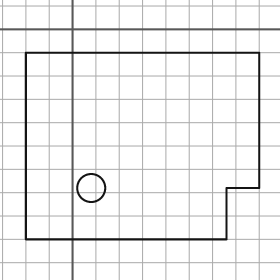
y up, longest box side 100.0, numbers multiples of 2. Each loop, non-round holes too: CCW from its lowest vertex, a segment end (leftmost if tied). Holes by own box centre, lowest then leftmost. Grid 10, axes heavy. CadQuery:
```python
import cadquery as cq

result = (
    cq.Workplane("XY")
    .moveTo(-20.0, -90.0)
    .lineTo(66.0, -90.0)
    .lineTo(66.0, -68.0)
    .lineTo(80.0, -68.0)
    .lineTo(80.0, -10.0)
    .lineTo(-20.0, -10.0)
    .close()
    .moveTo(8.0, -68.0)
    .circle(6.0)
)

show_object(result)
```